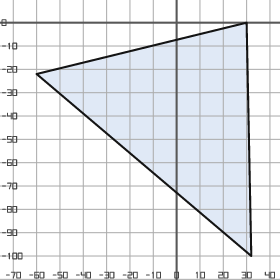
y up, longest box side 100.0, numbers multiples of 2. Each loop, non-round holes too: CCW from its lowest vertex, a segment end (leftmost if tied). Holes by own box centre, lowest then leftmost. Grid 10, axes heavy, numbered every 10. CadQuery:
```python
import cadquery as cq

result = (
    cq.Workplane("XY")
    .moveTo(32.0, -100.0)
    .lineTo(30.0, 0.0)
    .lineTo(-60.0, -22.0)
    .close()
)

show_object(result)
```